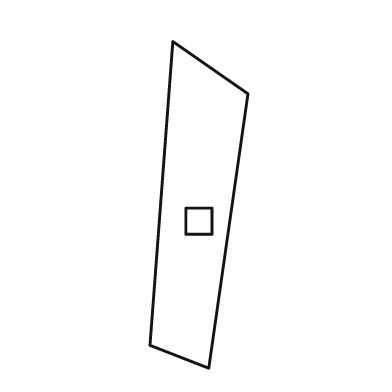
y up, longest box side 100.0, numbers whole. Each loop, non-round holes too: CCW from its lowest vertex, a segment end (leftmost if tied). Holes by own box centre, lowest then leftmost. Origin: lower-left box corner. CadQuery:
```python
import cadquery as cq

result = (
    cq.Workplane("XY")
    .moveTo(18.0, 0.0)
    .lineTo(30.0, 84.0)
    .lineTo(7.0, 100.0)
    .lineTo(0.0, 7.0)
    .close()
    .moveTo(11.0, 41.0)
    .lineTo(19.0, 41.0)
    .lineTo(19.0, 49.0)
    .lineTo(11.0, 49.0)
    .close()
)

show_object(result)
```